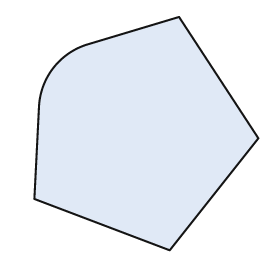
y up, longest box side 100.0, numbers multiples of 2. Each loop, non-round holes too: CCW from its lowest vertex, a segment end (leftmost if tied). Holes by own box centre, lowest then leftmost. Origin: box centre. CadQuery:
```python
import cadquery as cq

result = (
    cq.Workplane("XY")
    .moveTo(10.0, -50.0)
    .lineTo(48.0, -2.0)
    .lineTo(14.0, 50.0)
    .lineTo(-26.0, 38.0)
    .threePointArc((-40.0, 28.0), (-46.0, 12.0))
    .lineTo(-48.0, -28.0)
    .close()
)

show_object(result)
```